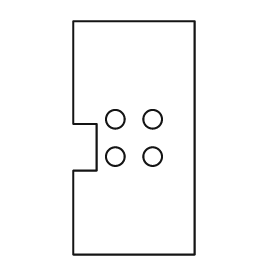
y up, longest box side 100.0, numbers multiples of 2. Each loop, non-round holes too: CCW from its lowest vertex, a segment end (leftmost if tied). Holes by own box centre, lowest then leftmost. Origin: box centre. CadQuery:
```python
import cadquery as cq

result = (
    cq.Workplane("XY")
    .moveTo(-26.0, -50.0)
    .lineTo(26.0, -50.0)
    .lineTo(26.0, 50.0)
    .lineTo(-26.0, 50.0)
    .lineTo(-26.0, 6.0)
    .lineTo(-16.0, 6.0)
    .lineTo(-16.0, -14.0)
    .lineTo(-26.0, -14.0)
    .close()
    .moveTo(-8.0, -8.0)
    .circle(4.0)
    .moveTo(8.0, -8.0)
    .circle(4.0)
    .moveTo(-8.0, 8.0)
    .circle(4.0)
    .moveTo(8.0, 8.0)
    .circle(4.0)
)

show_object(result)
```